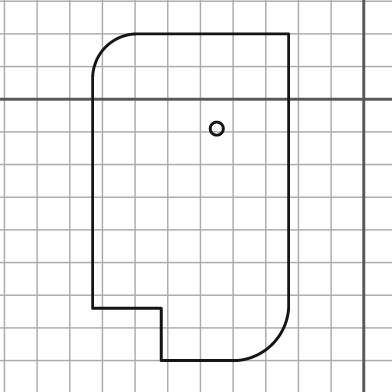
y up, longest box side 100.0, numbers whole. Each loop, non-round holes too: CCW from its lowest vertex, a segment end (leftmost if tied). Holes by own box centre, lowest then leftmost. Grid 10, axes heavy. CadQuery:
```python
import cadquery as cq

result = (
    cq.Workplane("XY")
    .moveTo(-62.0, -80.0)
    .lineTo(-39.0, -80.0)
    .threePointArc((-28.0, -75.0), (-23.0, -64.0))
    .lineTo(-23.0, 20.0)
    .lineTo(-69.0, 20.0)
    .threePointArc((-79.0, 16.0), (-83.0, 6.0))
    .lineTo(-83.0, -64.0)
    .lineTo(-62.0, -64.0)
    .close()
    .moveTo(-45.0, -9.0)
    .circle(2.0)
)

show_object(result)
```